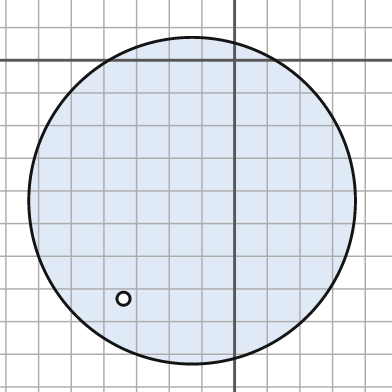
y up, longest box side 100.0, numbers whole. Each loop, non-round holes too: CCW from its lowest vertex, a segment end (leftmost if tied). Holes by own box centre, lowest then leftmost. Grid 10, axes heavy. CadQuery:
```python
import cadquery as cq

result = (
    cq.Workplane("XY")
    .moveTo(-13.0, -43.0)
    .circle(50.0)
    .moveTo(-34.0, -73.0)
    .circle(2.0)
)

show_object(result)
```